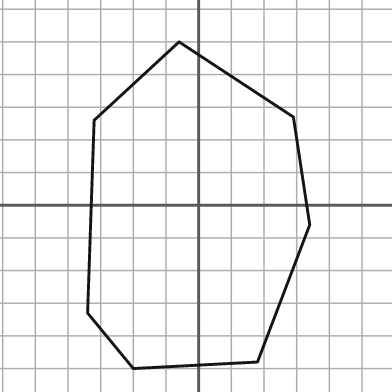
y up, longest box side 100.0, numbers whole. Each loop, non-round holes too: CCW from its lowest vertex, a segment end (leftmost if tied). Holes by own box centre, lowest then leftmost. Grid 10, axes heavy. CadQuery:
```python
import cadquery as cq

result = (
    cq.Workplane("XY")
    .moveTo(-20.0, -50.0)
    .lineTo(18.0, -48.0)
    .lineTo(34.0, -6.0)
    .lineTo(29.0, 27.0)
    .lineTo(-6.0, 50.0)
    .lineTo(-32.0, 26.0)
    .lineTo(-34.0, -33.0)
    .close()
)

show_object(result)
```